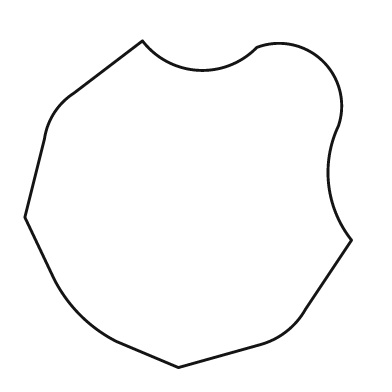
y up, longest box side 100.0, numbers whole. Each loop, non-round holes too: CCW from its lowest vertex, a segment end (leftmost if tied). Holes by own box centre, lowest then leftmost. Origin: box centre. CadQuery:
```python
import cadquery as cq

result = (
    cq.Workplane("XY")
    .moveTo(-3.0, -50.0)
    .lineTo(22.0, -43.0)
    .threePointArc((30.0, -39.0), (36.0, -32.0))
    .lineTo(50.0, -11.0)
    .threePointArc((43.0, 6.0), (46.0, 24.0))
    .threePointArc((41.0, 44.0), (21.0, 48.0))
    .threePointArc((3.0, 41.0), (-14.0, 50.0))
    .lineTo(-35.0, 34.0)
    .threePointArc((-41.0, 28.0), (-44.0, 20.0))
    .lineTo(-50.0, -4.0)
    .lineTo(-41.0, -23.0)
    .threePointArc((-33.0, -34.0), (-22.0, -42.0))
    .close()
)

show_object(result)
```